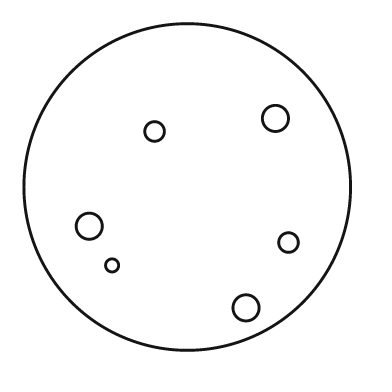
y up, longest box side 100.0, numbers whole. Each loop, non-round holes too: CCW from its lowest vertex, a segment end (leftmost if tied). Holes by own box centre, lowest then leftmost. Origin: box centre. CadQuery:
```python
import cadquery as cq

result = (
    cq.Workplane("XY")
    .moveTo(0.0, 0.0)
    .circle(50.0)
    .moveTo(18.0, -37.0)
    .circle(4.0)
    .moveTo(-23.0, -24.0)
    .circle(2.0)
    .moveTo(31.0, -17.0)
    .circle(3.0)
    .moveTo(-30.0, -12.0)
    .circle(4.0)
    .moveTo(-10.0, 17.0)
    .circle(3.0)
    .moveTo(27.0, 21.0)
    .circle(4.0)
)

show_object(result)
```